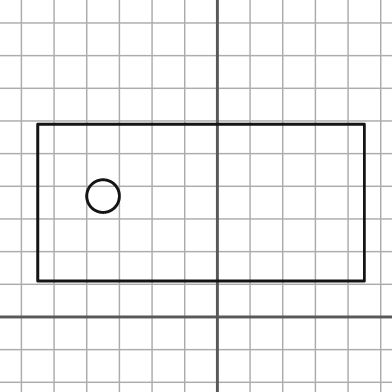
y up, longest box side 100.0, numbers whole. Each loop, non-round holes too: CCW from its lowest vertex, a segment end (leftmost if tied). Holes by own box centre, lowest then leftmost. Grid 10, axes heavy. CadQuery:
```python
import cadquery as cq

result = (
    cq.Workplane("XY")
    .moveTo(-55.0, 11.0)
    .lineTo(45.0, 11.0)
    .lineTo(45.0, 59.0)
    .lineTo(-55.0, 59.0)
    .close()
    .moveTo(-35.0, 37.0)
    .circle(5.0)
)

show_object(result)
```